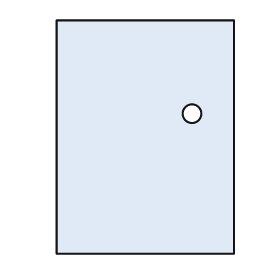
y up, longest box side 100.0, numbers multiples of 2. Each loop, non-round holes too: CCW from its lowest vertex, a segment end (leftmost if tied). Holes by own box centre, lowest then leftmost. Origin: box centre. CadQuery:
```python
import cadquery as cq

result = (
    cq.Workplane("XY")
    .moveTo(-38.0, -50.0)
    .lineTo(38.0, -50.0)
    .lineTo(38.0, 50.0)
    .lineTo(-38.0, 50.0)
    .close()
    .moveTo(20.0, 10.0)
    .circle(4.0)
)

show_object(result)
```